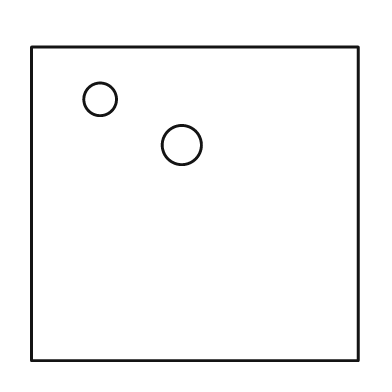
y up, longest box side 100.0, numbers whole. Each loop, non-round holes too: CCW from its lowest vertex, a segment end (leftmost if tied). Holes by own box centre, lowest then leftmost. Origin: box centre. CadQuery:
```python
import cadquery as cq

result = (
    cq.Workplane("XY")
    .moveTo(-50.0, -48.0)
    .lineTo(50.0, -48.0)
    .lineTo(50.0, 48.0)
    .lineTo(-50.0, 48.0)
    .close()
    .moveTo(-4.0, 18.0)
    .circle(6.0)
    .moveTo(-29.0, 32.0)
    .circle(5.0)
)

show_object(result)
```